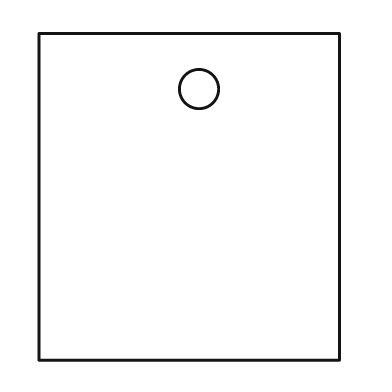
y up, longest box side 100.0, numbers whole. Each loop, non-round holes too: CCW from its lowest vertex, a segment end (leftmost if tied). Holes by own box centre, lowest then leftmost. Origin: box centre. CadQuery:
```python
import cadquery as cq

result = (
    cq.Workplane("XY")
    .moveTo(-46.0, -50.0)
    .lineTo(46.0, -50.0)
    .lineTo(46.0, 50.0)
    .lineTo(-46.0, 50.0)
    .close()
    .moveTo(3.0, 33.0)
    .circle(6.0)
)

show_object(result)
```